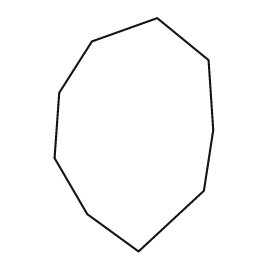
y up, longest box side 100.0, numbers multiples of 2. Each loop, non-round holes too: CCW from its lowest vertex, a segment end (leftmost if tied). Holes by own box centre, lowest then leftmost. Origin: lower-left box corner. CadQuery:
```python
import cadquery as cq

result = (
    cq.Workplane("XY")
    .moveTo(36.0, 0.0)
    .lineTo(64.0, 26.0)
    .lineTo(68.0, 52.0)
    .lineTo(66.0, 82.0)
    .lineTo(44.0, 100.0)
    .lineTo(16.0, 90.0)
    .lineTo(2.0, 68.0)
    .lineTo(0.0, 40.0)
    .lineTo(14.0, 16.0)
    .close()
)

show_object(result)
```